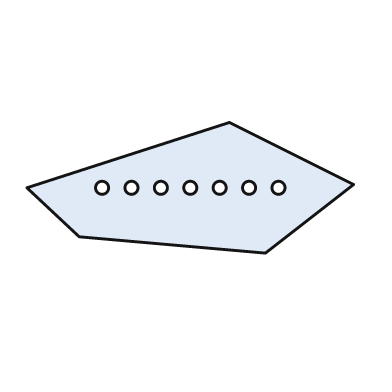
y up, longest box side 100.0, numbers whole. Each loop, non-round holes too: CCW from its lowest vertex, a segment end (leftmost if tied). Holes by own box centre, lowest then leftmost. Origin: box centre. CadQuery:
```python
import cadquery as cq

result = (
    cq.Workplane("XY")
    .moveTo(23.0, -20.0)
    .lineTo(50.0, 1.0)
    .lineTo(12.0, 20.0)
    .lineTo(-50.0, 0.0)
    .lineTo(-34.0, -15.0)
    .close()
    .moveTo(-27.0, 0.0)
    .circle(2.0)
    .moveTo(-18.0, 0.0)
    .circle(2.0)
    .moveTo(-9.0, 0.0)
    .circle(2.0)
    .moveTo(0.0, 0.0)
    .circle(2.0)
    .moveTo(9.0, 0.0)
    .circle(2.0)
    .moveTo(18.0, 0.0)
    .circle(2.0)
    .moveTo(27.0, 0.0)
    .circle(2.0)
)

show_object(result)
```